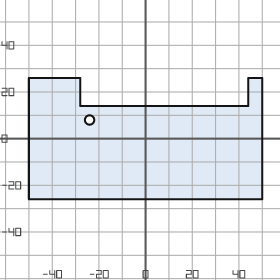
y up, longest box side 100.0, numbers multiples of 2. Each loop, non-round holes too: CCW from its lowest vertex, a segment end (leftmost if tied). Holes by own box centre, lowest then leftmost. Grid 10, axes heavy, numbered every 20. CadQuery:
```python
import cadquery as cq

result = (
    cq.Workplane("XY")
    .moveTo(-50.0, -26.0)
    .lineTo(50.0, -26.0)
    .lineTo(50.0, 26.0)
    .lineTo(44.0, 26.0)
    .lineTo(44.0, 14.0)
    .lineTo(-28.0, 14.0)
    .lineTo(-28.0, 26.0)
    .lineTo(-50.0, 26.0)
    .close()
    .moveTo(-24.0, 8.0)
    .circle(2.0)
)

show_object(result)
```